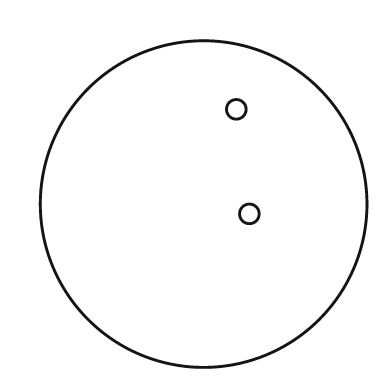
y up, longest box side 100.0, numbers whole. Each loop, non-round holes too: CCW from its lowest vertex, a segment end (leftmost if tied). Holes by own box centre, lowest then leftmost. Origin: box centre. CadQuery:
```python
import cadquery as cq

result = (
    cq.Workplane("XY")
    .moveTo(0.0, 0.0)
    .circle(50.0)
    .moveTo(14.0, -3.0)
    .circle(3.0)
    .moveTo(10.0, 29.0)
    .circle(3.0)
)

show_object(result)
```